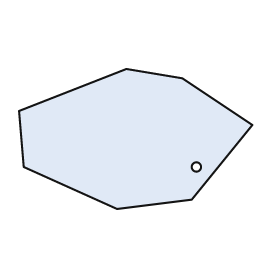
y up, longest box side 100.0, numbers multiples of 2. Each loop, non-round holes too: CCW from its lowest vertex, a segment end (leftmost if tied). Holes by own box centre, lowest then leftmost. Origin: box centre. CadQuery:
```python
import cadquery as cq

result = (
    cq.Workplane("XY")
    .moveTo(-8.0, -30.0)
    .lineTo(24.0, -26.0)
    .lineTo(50.0, 6.0)
    .lineTo(20.0, 26.0)
    .lineTo(-4.0, 30.0)
    .lineTo(-50.0, 12.0)
    .lineTo(-48.0, -12.0)
    .close()
    .moveTo(26.0, -12.0)
    .circle(2.0)
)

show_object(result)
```